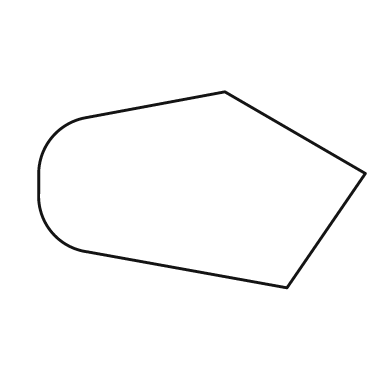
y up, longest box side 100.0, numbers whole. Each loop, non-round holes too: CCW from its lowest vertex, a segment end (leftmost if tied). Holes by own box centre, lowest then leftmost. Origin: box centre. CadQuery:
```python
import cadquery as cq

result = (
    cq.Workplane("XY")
    .moveTo(26.0, -30.0)
    .lineTo(50.0, 5.0)
    .lineTo(7.0, 30.0)
    .lineTo(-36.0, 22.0)
    .threePointArc((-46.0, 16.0), (-50.0, 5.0))
    .lineTo(-50.0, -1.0)
    .threePointArc((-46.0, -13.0), (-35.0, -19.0))
    .close()
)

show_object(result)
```